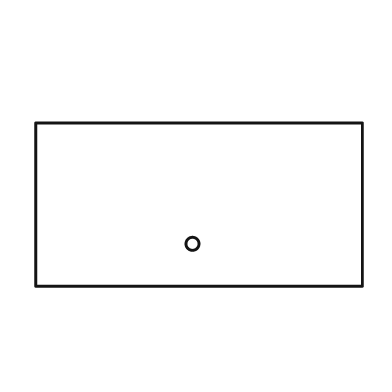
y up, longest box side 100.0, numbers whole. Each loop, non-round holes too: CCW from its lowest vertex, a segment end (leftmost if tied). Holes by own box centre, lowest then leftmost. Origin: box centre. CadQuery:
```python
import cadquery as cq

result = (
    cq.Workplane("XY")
    .moveTo(-50.0, -25.0)
    .lineTo(50.0, -25.0)
    .lineTo(50.0, 25.0)
    .lineTo(-50.0, 25.0)
    .close()
    .moveTo(-2.0, -12.0)
    .circle(2.0)
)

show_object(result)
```